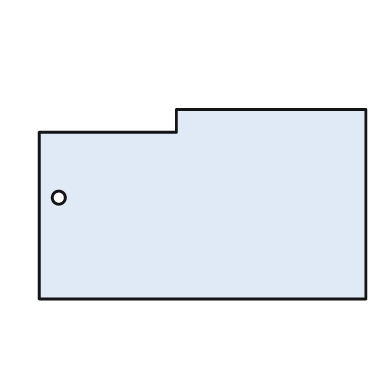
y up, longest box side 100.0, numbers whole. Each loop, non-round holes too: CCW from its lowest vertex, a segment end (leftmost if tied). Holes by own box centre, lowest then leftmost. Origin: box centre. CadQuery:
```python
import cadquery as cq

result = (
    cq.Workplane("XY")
    .moveTo(-50.0, -29.0)
    .lineTo(50.0, -29.0)
    .lineTo(50.0, 29.0)
    .lineTo(-8.0, 29.0)
    .lineTo(-8.0, 22.0)
    .lineTo(-50.0, 22.0)
    .close()
    .moveTo(-44.0, 2.0)
    .circle(2.0)
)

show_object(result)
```